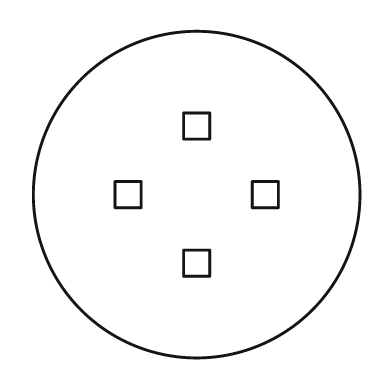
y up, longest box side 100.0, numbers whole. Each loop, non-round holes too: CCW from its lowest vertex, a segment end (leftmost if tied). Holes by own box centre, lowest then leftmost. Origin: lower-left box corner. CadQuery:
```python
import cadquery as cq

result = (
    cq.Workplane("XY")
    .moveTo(50.0, 50.0)
    .circle(50.0)
    .moveTo(46.0, 25.0)
    .lineTo(54.0, 25.0)
    .lineTo(54.0, 33.0)
    .lineTo(46.0, 33.0)
    .close()
    .moveTo(25.0, 46.0)
    .lineTo(33.0, 46.0)
    .lineTo(33.0, 54.0)
    .lineTo(25.0, 54.0)
    .close()
    .moveTo(67.0, 46.0)
    .lineTo(75.0, 46.0)
    .lineTo(75.0, 54.0)
    .lineTo(67.0, 54.0)
    .close()
    .moveTo(46.0, 67.0)
    .lineTo(54.0, 67.0)
    .lineTo(54.0, 75.0)
    .lineTo(46.0, 75.0)
    .close()
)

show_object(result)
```